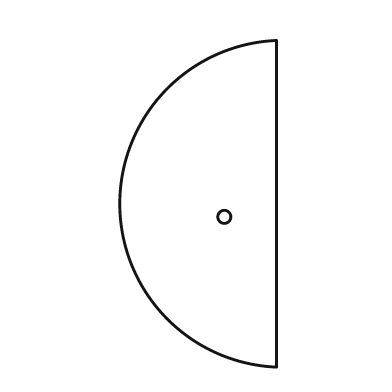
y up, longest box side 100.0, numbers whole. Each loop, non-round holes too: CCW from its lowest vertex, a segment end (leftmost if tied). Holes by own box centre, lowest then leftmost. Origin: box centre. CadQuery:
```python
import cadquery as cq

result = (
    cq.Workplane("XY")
    .moveTo(24.0, -50.0)
    .lineTo(24.0, 50.0)
    .threePointArc((-24.0, 0.0), (24.0, -50.0))
    .close()
    .moveTo(8.0, -4.0)
    .circle(2.0)
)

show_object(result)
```